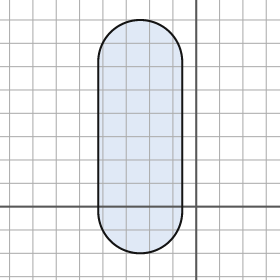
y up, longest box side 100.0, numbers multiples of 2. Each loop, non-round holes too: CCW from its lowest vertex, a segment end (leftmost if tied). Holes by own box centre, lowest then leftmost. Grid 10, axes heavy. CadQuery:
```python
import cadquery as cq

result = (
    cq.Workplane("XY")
    .moveTo(-42.0, -2.0)
    .threePointArc((-24.0, -20.0), (-6.0, -2.0))
    .lineTo(-6.0, 62.0)
    .threePointArc((-24.0, 80.0), (-42.0, 62.0))
    .close()
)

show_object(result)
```